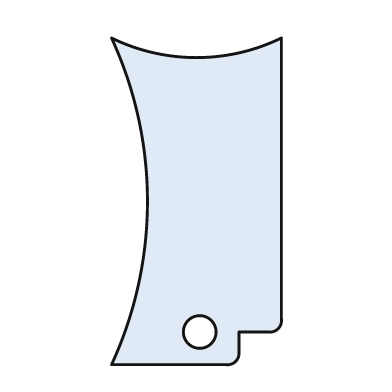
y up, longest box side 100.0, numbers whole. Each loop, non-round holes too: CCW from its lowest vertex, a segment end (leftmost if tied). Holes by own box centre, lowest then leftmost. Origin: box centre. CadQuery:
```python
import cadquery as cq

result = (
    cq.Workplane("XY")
    .moveTo(-26.0, -50.0)
    .lineTo(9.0, -50.0)
    .threePointArc((12.0, -49.0), (13.0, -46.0))
    .lineTo(13.0, -40.0)
    .lineTo(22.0, -40.0)
    .threePointArc((25.0, -39.0), (26.0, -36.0))
    .lineTo(26.0, 50.0)
    .threePointArc((0.0, 44.0), (-26.0, 50.0))
    .threePointArc((-15.0, 0.0), (-26.0, -50.0))
    .close()
    .moveTo(1.0, -40.0)
    .circle(5.0)
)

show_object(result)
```